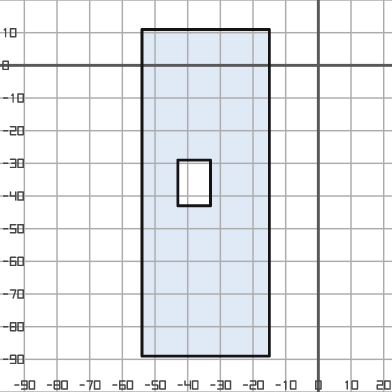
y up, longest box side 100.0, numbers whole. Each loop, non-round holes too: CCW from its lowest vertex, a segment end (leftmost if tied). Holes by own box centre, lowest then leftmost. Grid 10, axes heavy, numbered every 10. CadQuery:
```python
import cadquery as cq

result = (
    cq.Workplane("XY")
    .moveTo(-54.0, -89.0)
    .lineTo(-15.0, -89.0)
    .lineTo(-15.0, 11.0)
    .lineTo(-54.0, 11.0)
    .close()
    .moveTo(-43.0, -43.0)
    .lineTo(-33.0, -43.0)
    .lineTo(-33.0, -29.0)
    .lineTo(-43.0, -29.0)
    .close()
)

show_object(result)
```